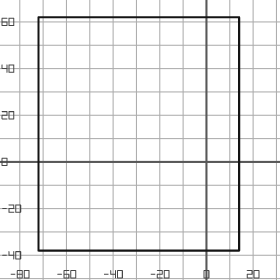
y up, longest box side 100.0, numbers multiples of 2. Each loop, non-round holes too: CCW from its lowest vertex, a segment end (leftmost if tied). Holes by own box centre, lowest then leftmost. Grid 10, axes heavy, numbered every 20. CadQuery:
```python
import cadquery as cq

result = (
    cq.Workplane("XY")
    .moveTo(-72.0, -38.0)
    .lineTo(14.0, -38.0)
    .lineTo(14.0, 62.0)
    .lineTo(-72.0, 62.0)
    .close()
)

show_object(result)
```